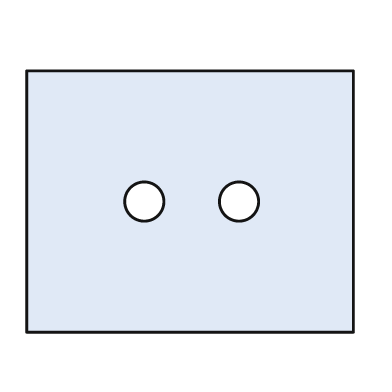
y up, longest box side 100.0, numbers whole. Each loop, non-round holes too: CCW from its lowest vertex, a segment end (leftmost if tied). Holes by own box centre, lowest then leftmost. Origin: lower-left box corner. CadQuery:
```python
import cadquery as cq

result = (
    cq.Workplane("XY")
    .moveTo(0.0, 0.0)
    .lineTo(100.0, 0.0)
    .lineTo(100.0, 80.0)
    .lineTo(0.0, 80.0)
    .close()
    .moveTo(36.0, 40.0)
    .circle(6.0)
    .moveTo(65.0, 40.0)
    .circle(6.0)
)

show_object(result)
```